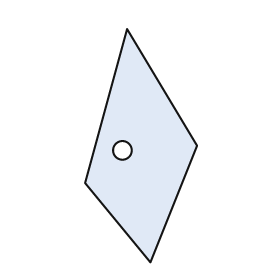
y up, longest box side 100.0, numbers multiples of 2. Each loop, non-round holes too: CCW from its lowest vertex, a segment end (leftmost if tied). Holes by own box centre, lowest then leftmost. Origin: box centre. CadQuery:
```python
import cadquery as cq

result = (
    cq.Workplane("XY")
    .moveTo(4.0, -50.0)
    .lineTo(24.0, 0.0)
    .lineTo(-6.0, 50.0)
    .lineTo(-24.0, -16.0)
    .close()
    .moveTo(-8.0, -2.0)
    .circle(4.0)
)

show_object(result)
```